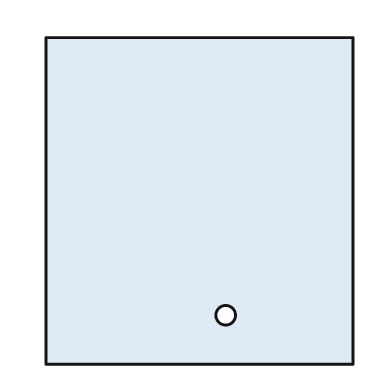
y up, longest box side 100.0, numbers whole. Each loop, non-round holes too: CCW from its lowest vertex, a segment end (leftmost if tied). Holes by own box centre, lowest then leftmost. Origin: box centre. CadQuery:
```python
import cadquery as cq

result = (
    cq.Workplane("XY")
    .moveTo(-47.0, -50.0)
    .lineTo(47.0, -50.0)
    .lineTo(47.0, 50.0)
    .lineTo(-47.0, 50.0)
    .close()
    .moveTo(8.0, -35.0)
    .circle(3.0)
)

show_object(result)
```